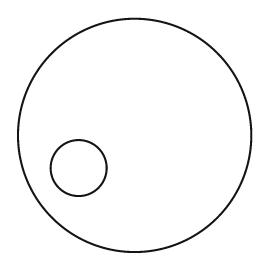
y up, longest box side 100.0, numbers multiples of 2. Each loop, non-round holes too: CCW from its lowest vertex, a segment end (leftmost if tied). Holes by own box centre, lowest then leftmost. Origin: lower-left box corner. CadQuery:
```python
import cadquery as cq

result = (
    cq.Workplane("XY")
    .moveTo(50.0, 50.0)
    .circle(50.0)
    .moveTo(26.0, 36.0)
    .circle(12.0)
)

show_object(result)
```